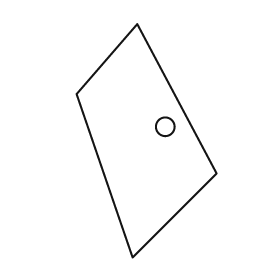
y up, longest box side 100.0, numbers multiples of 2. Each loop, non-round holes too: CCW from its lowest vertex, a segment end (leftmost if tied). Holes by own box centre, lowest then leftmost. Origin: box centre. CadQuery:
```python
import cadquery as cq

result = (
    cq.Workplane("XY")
    .moveTo(-6.0, -50.0)
    .lineTo(30.0, -14.0)
    .lineTo(-4.0, 50.0)
    .lineTo(-30.0, 20.0)
    .close()
    .moveTo(8.0, 6.0)
    .circle(4.0)
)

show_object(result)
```